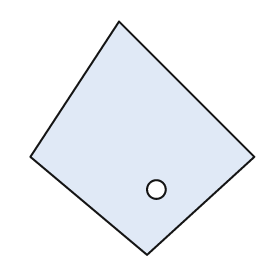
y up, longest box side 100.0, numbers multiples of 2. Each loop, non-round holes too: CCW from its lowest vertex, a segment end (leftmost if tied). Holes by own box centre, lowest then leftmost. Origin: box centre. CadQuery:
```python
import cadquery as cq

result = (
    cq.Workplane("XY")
    .moveTo(2.0, -50.0)
    .lineTo(48.0, -8.0)
    .lineTo(-10.0, 50.0)
    .lineTo(-48.0, -8.0)
    .close()
    .moveTo(6.0, -22.0)
    .circle(4.0)
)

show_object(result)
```